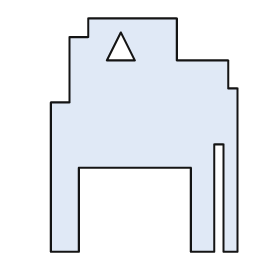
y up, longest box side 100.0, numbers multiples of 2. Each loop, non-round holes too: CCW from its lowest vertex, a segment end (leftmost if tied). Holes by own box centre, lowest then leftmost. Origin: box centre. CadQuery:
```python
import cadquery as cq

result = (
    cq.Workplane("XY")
    .moveTo(-40.0, -50.0)
    .lineTo(-28.0, -50.0)
    .lineTo(-28.0, -14.0)
    .lineTo(20.0, -14.0)
    .lineTo(20.0, -50.0)
    .lineTo(30.0, -50.0)
    .lineTo(30.0, -4.0)
    .lineTo(34.0, -4.0)
    .lineTo(34.0, -50.0)
    .lineTo(40.0, -50.0)
    .lineTo(40.0, 20.0)
    .lineTo(36.0, 20.0)
    .lineTo(36.0, 32.0)
    .lineTo(14.0, 32.0)
    .lineTo(14.0, 50.0)
    .lineTo(-24.0, 50.0)
    .lineTo(-24.0, 42.0)
    .lineTo(-32.0, 42.0)
    .lineTo(-32.0, 14.0)
    .lineTo(-40.0, 14.0)
    .close()
    .moveTo(-16.0, 32.0)
    .lineTo(-4.0, 32.0)
    .lineTo(-10.0, 44.0)
    .close()
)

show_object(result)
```